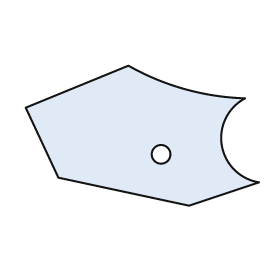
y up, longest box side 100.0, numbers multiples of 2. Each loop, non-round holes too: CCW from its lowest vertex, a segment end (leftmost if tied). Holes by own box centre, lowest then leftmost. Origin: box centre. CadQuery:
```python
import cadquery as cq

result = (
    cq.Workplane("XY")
    .moveTo(20.0, -30.0)
    .lineTo(50.0, -20.0)
    .threePointArc((34.0, -4.0), (44.0, 16.0))
    .threePointArc((18.0, 20.0), (-6.0, 30.0))
    .lineTo(-50.0, 12.0)
    .lineTo(-36.0, -18.0)
    .close()
    .moveTo(8.0, -8.0)
    .circle(4.0)
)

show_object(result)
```